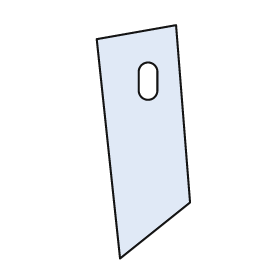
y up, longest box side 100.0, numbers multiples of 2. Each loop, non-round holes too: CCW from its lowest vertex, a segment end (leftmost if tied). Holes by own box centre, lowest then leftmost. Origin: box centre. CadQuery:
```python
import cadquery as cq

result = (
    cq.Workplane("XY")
    .moveTo(-10.0, -50.0)
    .lineTo(20.0, -26.0)
    .lineTo(14.0, 50.0)
    .lineTo(-20.0, 44.0)
    .close()
    .moveTo(-2.0, 22.0)
    .threePointArc((2.0, 18.0), (6.0, 22.0))
    .lineTo(6.0, 30.0)
    .threePointArc((2.0, 34.0), (-2.0, 30.0))
    .close()
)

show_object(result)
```